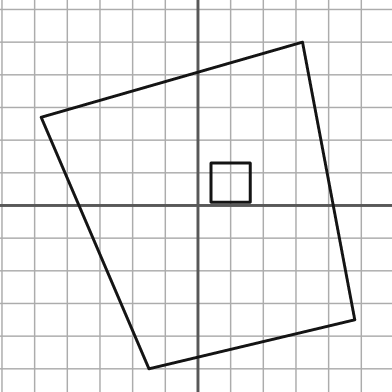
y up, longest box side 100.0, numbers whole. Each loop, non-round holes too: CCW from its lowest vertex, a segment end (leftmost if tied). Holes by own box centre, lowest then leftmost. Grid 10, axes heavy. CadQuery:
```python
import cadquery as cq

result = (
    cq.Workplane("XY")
    .moveTo(-15.0, -50.0)
    .lineTo(48.0, -35.0)
    .lineTo(32.0, 50.0)
    .lineTo(-48.0, 27.0)
    .close()
    .moveTo(4.0, 1.0)
    .lineTo(16.0, 1.0)
    .lineTo(16.0, 13.0)
    .lineTo(4.0, 13.0)
    .close()
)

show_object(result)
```